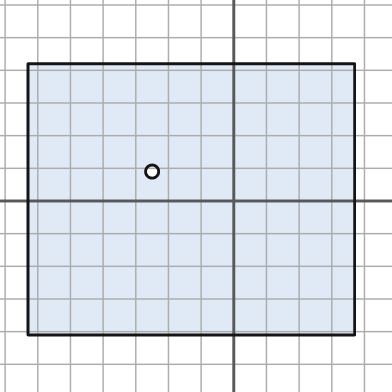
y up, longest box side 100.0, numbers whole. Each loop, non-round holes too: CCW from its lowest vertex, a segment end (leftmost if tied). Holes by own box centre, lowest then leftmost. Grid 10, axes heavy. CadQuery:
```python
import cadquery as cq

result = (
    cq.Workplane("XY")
    .moveTo(-63.0, -41.0)
    .lineTo(37.0, -41.0)
    .lineTo(37.0, 42.0)
    .lineTo(-63.0, 42.0)
    .close()
    .moveTo(-25.0, 9.0)
    .circle(2.0)
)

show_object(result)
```